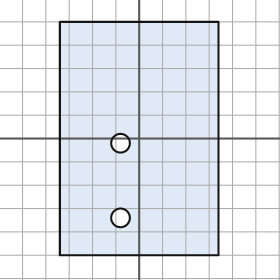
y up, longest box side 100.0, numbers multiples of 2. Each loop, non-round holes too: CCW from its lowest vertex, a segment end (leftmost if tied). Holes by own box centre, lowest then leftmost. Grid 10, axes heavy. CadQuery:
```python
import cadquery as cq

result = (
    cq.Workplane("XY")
    .moveTo(-34.0, -50.0)
    .lineTo(34.0, -50.0)
    .lineTo(34.0, 50.0)
    .lineTo(-34.0, 50.0)
    .close()
    .moveTo(-8.0, -34.0)
    .circle(4.0)
    .moveTo(-8.0, -2.0)
    .circle(4.0)
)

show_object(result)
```